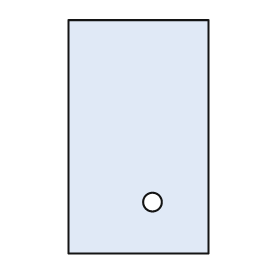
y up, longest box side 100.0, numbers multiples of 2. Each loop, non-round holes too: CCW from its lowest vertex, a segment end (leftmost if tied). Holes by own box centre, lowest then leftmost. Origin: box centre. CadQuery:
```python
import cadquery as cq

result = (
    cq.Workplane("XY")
    .moveTo(-30.0, -50.0)
    .lineTo(30.0, -50.0)
    .lineTo(30.0, 50.0)
    .lineTo(-30.0, 50.0)
    .close()
    .moveTo(6.0, -28.0)
    .circle(4.0)
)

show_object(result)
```